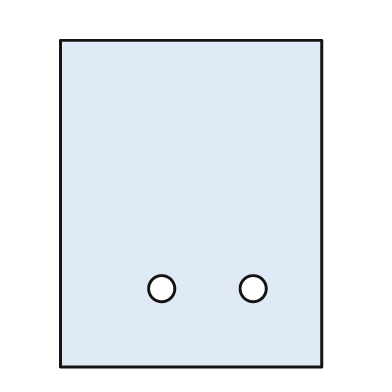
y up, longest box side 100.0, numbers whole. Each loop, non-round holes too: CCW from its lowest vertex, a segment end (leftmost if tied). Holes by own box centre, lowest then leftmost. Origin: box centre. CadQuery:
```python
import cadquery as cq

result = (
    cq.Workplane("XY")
    .moveTo(-40.0, -50.0)
    .lineTo(40.0, -50.0)
    .lineTo(40.0, 50.0)
    .lineTo(-40.0, 50.0)
    .close()
    .moveTo(-9.0, -26.0)
    .circle(4.0)
    .moveTo(19.0, -26.0)
    .circle(4.0)
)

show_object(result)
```